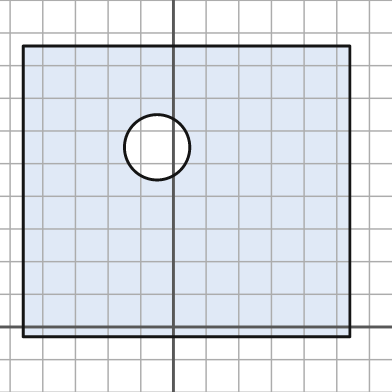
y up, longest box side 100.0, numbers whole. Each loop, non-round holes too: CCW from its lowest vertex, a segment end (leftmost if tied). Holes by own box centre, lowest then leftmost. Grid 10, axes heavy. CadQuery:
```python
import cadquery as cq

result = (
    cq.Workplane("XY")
    .moveTo(-46.0, -3.0)
    .lineTo(54.0, -3.0)
    .lineTo(54.0, 86.0)
    .lineTo(-46.0, 86.0)
    .close()
    .moveTo(-5.0, 55.0)
    .circle(10.0)
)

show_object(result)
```